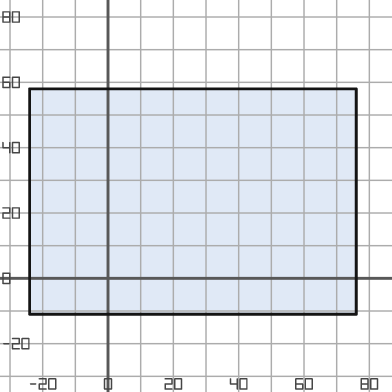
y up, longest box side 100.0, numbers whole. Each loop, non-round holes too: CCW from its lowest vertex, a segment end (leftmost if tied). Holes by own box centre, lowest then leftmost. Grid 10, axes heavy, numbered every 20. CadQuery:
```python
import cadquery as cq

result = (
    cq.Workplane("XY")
    .moveTo(-24.0, -11.0)
    .lineTo(76.0, -11.0)
    .lineTo(76.0, 58.0)
    .lineTo(-24.0, 58.0)
    .close()
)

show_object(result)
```